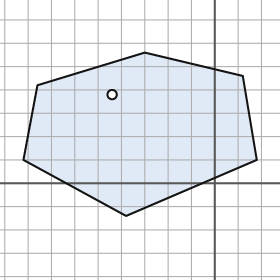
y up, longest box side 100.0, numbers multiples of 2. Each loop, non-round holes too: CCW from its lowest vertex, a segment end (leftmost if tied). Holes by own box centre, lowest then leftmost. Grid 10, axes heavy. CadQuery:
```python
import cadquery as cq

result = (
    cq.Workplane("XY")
    .moveTo(-38.0, -14.0)
    .lineTo(18.0, 10.0)
    .lineTo(12.0, 46.0)
    .lineTo(-30.0, 56.0)
    .lineTo(-76.0, 42.0)
    .lineTo(-82.0, 10.0)
    .close()
    .moveTo(-44.0, 38.0)
    .circle(2.0)
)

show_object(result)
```